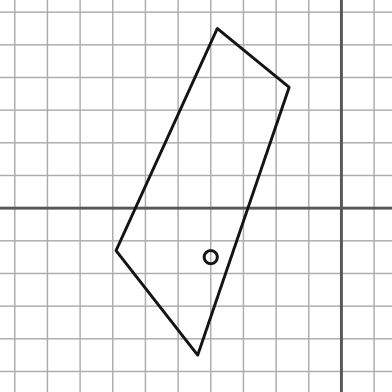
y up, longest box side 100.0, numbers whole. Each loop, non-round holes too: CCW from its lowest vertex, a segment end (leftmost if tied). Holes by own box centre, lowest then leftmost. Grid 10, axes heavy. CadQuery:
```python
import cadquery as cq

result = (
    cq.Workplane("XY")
    .moveTo(-44.0, -45.0)
    .lineTo(-16.0, 37.0)
    .lineTo(-38.0, 55.0)
    .lineTo(-69.0, -13.0)
    .close()
    .moveTo(-40.0, -15.0)
    .circle(2.0)
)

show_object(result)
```